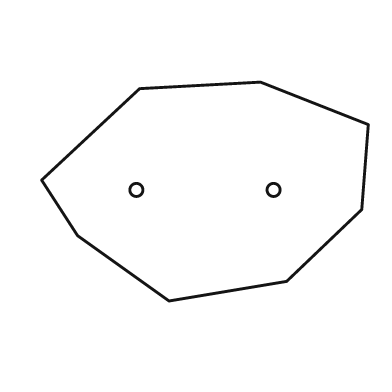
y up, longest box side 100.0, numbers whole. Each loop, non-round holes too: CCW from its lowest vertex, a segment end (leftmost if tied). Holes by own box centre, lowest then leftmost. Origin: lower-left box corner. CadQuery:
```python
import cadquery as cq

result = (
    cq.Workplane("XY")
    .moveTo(39.0, 0.0)
    .lineTo(75.0, 6.0)
    .lineTo(98.0, 28.0)
    .lineTo(100.0, 54.0)
    .lineTo(67.0, 67.0)
    .lineTo(30.0, 65.0)
    .lineTo(0.0, 37.0)
    .lineTo(11.0, 20.0)
    .close()
    .moveTo(29.0, 34.0)
    .circle(2.0)
    .moveTo(71.0, 34.0)
    .circle(2.0)
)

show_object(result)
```